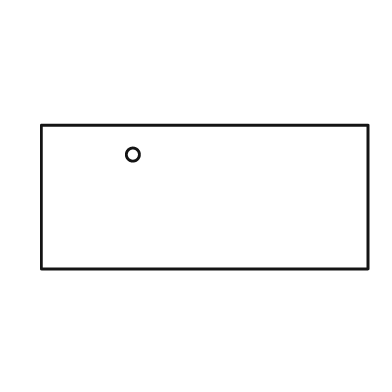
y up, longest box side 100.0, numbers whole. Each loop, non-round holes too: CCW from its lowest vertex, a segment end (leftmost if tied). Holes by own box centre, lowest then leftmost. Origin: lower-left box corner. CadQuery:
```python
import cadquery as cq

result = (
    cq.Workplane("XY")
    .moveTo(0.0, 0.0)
    .lineTo(100.0, 0.0)
    .lineTo(100.0, 44.0)
    .lineTo(0.0, 44.0)
    .close()
    .moveTo(28.0, 35.0)
    .circle(2.0)
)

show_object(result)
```